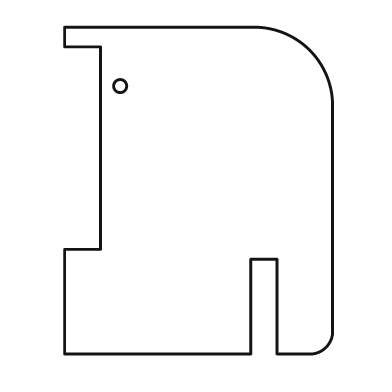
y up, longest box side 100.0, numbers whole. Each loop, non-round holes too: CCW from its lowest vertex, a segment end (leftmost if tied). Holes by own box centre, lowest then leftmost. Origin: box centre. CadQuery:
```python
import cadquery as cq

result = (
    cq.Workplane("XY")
    .moveTo(-41.0, -50.0)
    .lineTo(16.0, -50.0)
    .lineTo(16.0, -21.0)
    .lineTo(24.0, -21.0)
    .lineTo(24.0, -50.0)
    .lineTo(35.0, -50.0)
    .threePointArc((39.0, -48.0), (41.0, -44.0))
    .lineTo(41.0, 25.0)
    .threePointArc((34.0, 43.0), (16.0, 50.0))
    .lineTo(-41.0, 50.0)
    .lineTo(-41.0, 44.0)
    .lineTo(-30.0, 44.0)
    .lineTo(-30.0, -18.0)
    .lineTo(-41.0, -18.0)
    .close()
    .moveTo(-24.0, 32.0)
    .circle(2.0)
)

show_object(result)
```